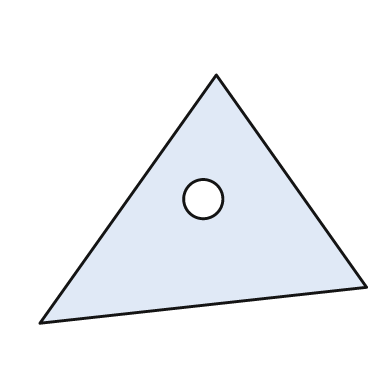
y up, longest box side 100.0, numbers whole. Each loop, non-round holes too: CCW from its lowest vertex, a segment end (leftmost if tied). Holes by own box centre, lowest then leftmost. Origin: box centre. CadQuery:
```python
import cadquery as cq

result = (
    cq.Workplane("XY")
    .moveTo(-50.0, -38.0)
    .lineTo(50.0, -27.0)
    .lineTo(4.0, 38.0)
    .close()
    .moveTo(0.0, 0.0)
    .circle(6.0)
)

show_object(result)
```